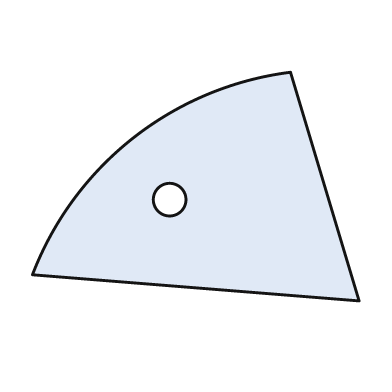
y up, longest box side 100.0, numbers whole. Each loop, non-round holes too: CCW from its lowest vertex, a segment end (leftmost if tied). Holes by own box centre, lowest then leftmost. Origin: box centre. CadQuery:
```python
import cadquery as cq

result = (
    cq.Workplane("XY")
    .moveTo(50.0, -35.0)
    .lineTo(29.0, 35.0)
    .threePointArc((-19.0, 15.0), (-50.0, -27.0))
    .close()
    .moveTo(-8.0, -4.0)
    .circle(5.0)
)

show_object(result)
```